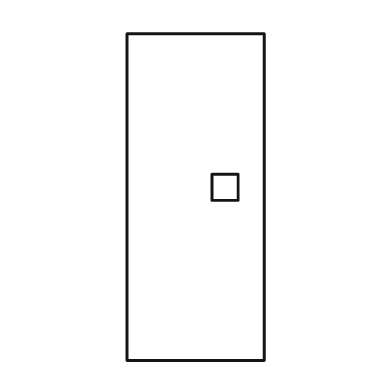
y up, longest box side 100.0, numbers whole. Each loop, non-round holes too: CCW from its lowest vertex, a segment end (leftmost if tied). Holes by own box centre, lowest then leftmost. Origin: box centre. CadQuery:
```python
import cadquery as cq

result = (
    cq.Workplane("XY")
    .moveTo(-21.0, -50.0)
    .lineTo(21.0, -50.0)
    .lineTo(21.0, 50.0)
    .lineTo(-21.0, 50.0)
    .close()
    .moveTo(5.0, -1.0)
    .lineTo(13.0, -1.0)
    .lineTo(13.0, 7.0)
    .lineTo(5.0, 7.0)
    .close()
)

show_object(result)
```